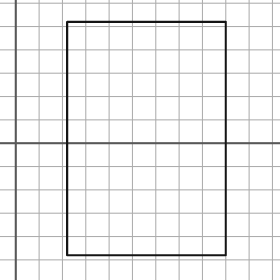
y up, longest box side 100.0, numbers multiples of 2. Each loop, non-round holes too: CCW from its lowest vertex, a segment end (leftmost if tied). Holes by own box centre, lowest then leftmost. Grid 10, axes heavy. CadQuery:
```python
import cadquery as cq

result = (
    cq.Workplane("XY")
    .moveTo(22.0, -48.0)
    .lineTo(90.0, -48.0)
    .lineTo(90.0, 52.0)
    .lineTo(22.0, 52.0)
    .close()
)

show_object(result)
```